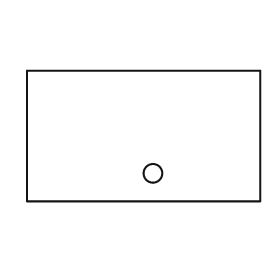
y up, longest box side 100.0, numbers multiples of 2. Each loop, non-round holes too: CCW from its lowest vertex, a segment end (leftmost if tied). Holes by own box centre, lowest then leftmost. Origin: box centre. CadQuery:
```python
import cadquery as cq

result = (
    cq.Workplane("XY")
    .moveTo(-50.0, -28.0)
    .lineTo(50.0, -28.0)
    .lineTo(50.0, 28.0)
    .lineTo(-50.0, 28.0)
    .close()
    .moveTo(4.0, -16.0)
    .circle(4.0)
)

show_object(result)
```